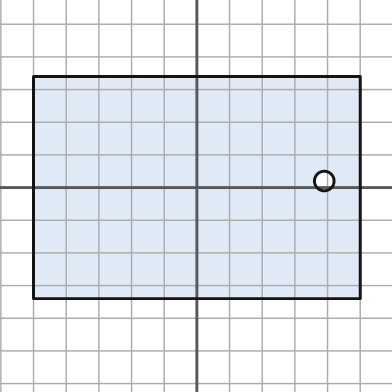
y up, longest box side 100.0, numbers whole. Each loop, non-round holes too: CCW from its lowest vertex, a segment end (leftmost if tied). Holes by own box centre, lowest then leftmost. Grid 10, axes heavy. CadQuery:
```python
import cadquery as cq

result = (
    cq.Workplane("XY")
    .moveTo(-50.0, -34.0)
    .lineTo(50.0, -34.0)
    .lineTo(50.0, 34.0)
    .lineTo(-50.0, 34.0)
    .close()
    .moveTo(39.0, 2.0)
    .circle(3.0)
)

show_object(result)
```